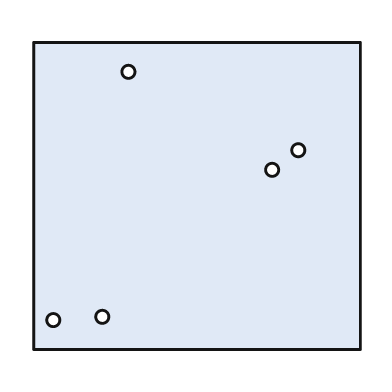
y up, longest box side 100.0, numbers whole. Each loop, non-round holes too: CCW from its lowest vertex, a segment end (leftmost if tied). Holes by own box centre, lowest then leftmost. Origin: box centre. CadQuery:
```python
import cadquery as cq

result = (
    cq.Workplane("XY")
    .moveTo(-50.0, -47.0)
    .lineTo(50.0, -47.0)
    .lineTo(50.0, 47.0)
    .lineTo(-50.0, 47.0)
    .close()
    .moveTo(-44.0, -38.0)
    .circle(2.0)
    .moveTo(-29.0, -37.0)
    .circle(2.0)
    .moveTo(23.0, 8.0)
    .circle(2.0)
    .moveTo(31.0, 14.0)
    .circle(2.0)
    .moveTo(-21.0, 38.0)
    .circle(2.0)
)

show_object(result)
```